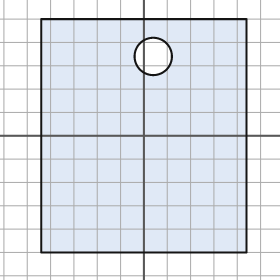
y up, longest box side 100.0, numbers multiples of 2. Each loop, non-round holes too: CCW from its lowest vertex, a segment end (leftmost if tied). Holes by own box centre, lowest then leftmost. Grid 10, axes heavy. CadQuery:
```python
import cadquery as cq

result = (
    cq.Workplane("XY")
    .moveTo(-44.0, -50.0)
    .lineTo(44.0, -50.0)
    .lineTo(44.0, 50.0)
    .lineTo(-44.0, 50.0)
    .close()
    .moveTo(4.0, 34.0)
    .circle(8.0)
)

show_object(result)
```